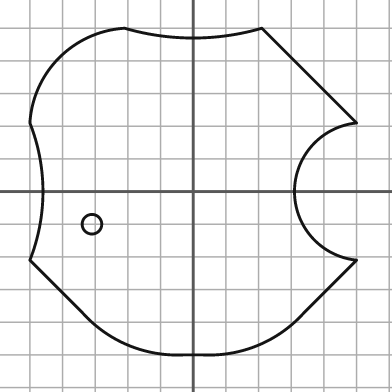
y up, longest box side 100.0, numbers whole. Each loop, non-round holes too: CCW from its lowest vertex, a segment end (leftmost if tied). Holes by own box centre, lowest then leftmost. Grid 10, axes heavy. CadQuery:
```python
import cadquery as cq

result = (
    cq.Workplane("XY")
    .moveTo(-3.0, -50.0)
    .lineTo(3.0, -50.0)
    .threePointArc((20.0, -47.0), (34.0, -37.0))
    .lineTo(50.0, -21.0)
    .threePointArc((31.0, 0.0), (50.0, 21.0))
    .lineTo(21.0, 50.0)
    .threePointArc((0.0, 47.0), (-21.0, 50.0))
    .threePointArc((-41.0, 41.0), (-50.0, 21.0))
    .threePointArc((-46.0, 0.0), (-50.0, -21.0))
    .lineTo(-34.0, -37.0)
    .threePointArc((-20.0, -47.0), (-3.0, -50.0))
    .close()
    .moveTo(-31.0, -10.0)
    .circle(3.0)
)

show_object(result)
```